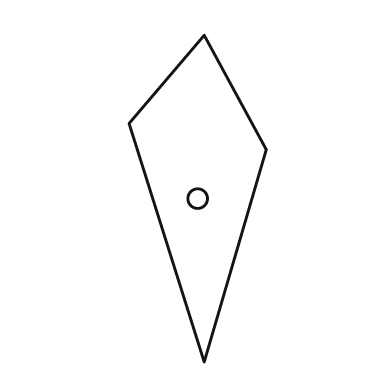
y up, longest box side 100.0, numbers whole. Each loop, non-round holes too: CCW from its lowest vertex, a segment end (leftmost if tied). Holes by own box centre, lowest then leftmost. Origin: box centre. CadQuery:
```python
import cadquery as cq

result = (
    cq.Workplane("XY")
    .moveTo(2.0, -50.0)
    .lineTo(21.0, 15.0)
    .lineTo(2.0, 50.0)
    .lineTo(-21.0, 23.0)
    .close()
    .moveTo(0.0, 0.0)
    .circle(3.0)
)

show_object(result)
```